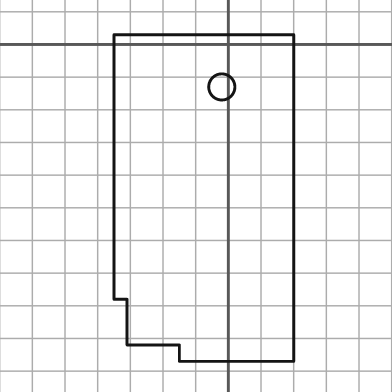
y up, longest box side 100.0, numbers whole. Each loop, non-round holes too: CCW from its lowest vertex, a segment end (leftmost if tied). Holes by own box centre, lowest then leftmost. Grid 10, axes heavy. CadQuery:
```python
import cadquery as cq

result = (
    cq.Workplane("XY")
    .moveTo(-15.0, -97.0)
    .lineTo(20.0, -97.0)
    .lineTo(20.0, 3.0)
    .lineTo(-35.0, 3.0)
    .lineTo(-35.0, -78.0)
    .lineTo(-31.0, -78.0)
    .lineTo(-31.0, -92.0)
    .lineTo(-15.0, -92.0)
    .close()
    .moveTo(-2.0, -13.0)
    .circle(4.0)
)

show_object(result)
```